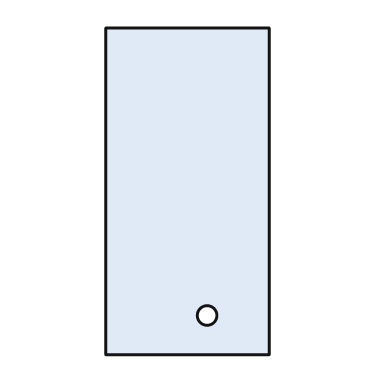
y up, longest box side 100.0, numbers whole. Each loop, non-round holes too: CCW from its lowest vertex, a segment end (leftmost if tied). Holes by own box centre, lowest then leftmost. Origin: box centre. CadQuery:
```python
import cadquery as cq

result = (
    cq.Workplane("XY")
    .moveTo(-25.0, -50.0)
    .lineTo(25.0, -50.0)
    .lineTo(25.0, 50.0)
    .lineTo(-25.0, 50.0)
    .close()
    .moveTo(6.0, -38.0)
    .circle(3.0)
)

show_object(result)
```